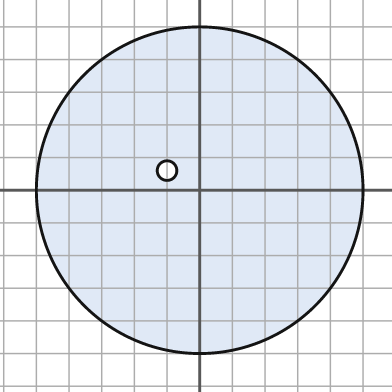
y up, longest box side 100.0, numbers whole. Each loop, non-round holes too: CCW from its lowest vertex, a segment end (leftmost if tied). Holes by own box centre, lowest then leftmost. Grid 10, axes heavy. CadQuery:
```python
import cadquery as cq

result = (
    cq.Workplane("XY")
    .moveTo(0.0, 0.0)
    .circle(50.0)
    .moveTo(-10.0, 6.0)
    .circle(3.0)
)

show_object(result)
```